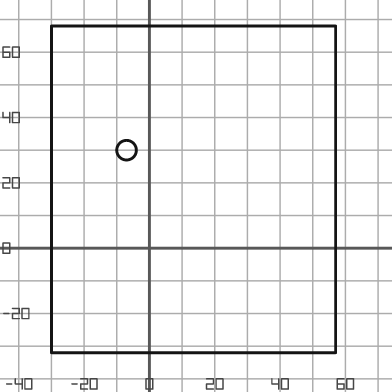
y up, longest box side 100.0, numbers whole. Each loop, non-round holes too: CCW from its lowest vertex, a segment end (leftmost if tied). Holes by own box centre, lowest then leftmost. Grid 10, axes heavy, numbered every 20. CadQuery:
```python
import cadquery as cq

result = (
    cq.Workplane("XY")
    .moveTo(-30.0, -32.0)
    .lineTo(57.0, -32.0)
    .lineTo(57.0, 68.0)
    .lineTo(-30.0, 68.0)
    .close()
    .moveTo(-7.0, 30.0)
    .circle(3.0)
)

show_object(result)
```